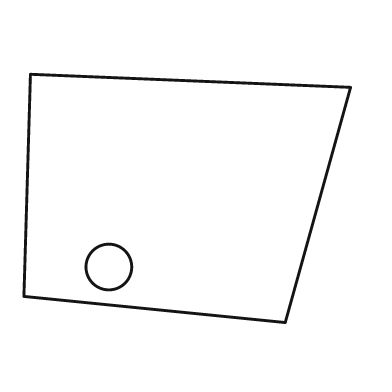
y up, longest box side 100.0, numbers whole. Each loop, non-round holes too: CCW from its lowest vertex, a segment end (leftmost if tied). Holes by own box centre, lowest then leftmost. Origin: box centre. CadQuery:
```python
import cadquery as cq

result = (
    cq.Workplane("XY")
    .moveTo(30.0, -38.0)
    .lineTo(50.0, 34.0)
    .lineTo(-48.0, 38.0)
    .lineTo(-50.0, -30.0)
    .close()
    .moveTo(-24.0, -21.0)
    .circle(7.0)
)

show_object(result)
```